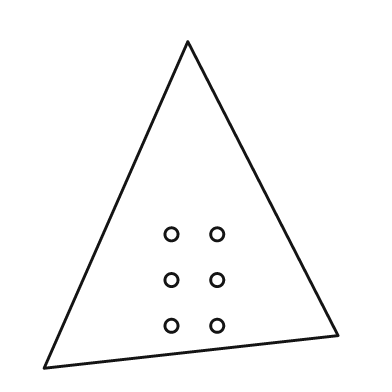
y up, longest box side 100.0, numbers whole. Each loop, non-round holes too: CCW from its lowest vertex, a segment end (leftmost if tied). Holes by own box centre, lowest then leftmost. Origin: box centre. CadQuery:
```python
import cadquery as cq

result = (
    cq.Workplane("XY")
    .moveTo(-45.0, -50.0)
    .lineTo(45.0, -40.0)
    .lineTo(-1.0, 50.0)
    .close()
    .moveTo(-6.0, -37.0)
    .circle(2.0)
    .moveTo(8.0, -37.0)
    .circle(2.0)
    .moveTo(-6.0, -23.0)
    .circle(2.0)
    .moveTo(8.0, -23.0)
    .circle(2.0)
    .moveTo(-6.0, -9.0)
    .circle(2.0)
    .moveTo(8.0, -9.0)
    .circle(2.0)
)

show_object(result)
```